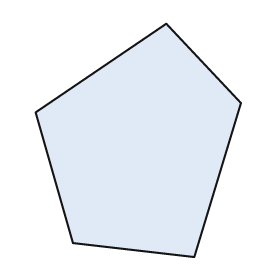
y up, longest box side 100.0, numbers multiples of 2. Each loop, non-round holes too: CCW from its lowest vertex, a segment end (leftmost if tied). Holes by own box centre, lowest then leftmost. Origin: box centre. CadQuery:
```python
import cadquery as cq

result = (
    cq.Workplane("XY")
    .moveTo(24.0, -50.0)
    .lineTo(44.0, 16.0)
    .lineTo(12.0, 50.0)
    .lineTo(-44.0, 12.0)
    .lineTo(-28.0, -44.0)
    .close()
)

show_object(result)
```